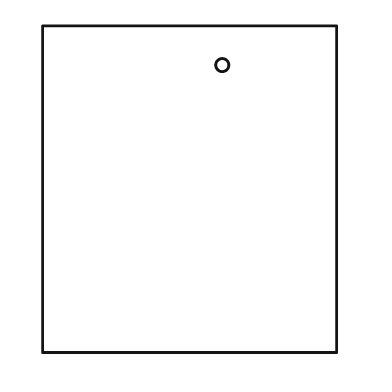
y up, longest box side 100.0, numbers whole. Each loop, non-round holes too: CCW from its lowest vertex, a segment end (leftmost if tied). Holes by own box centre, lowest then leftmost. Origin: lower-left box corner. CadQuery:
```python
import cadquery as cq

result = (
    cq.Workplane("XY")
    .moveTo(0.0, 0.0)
    .lineTo(90.0, 0.0)
    .lineTo(90.0, 100.0)
    .lineTo(0.0, 100.0)
    .close()
    .moveTo(55.0, 88.0)
    .circle(2.0)
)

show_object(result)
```